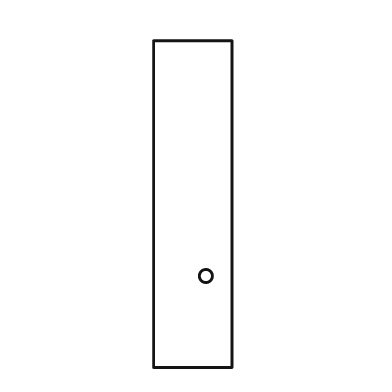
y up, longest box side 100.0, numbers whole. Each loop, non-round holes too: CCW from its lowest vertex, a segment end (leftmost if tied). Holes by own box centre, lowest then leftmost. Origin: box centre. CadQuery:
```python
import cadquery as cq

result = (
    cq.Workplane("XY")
    .moveTo(-12.0, -50.0)
    .lineTo(12.0, -50.0)
    .lineTo(12.0, 50.0)
    .lineTo(-12.0, 50.0)
    .close()
    .moveTo(4.0, -22.0)
    .circle(2.0)
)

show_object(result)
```